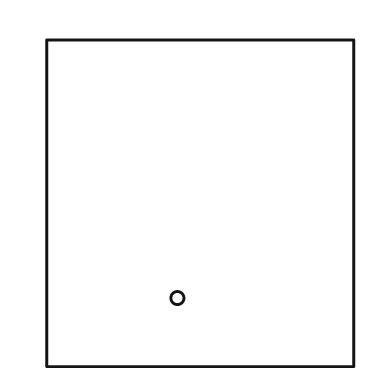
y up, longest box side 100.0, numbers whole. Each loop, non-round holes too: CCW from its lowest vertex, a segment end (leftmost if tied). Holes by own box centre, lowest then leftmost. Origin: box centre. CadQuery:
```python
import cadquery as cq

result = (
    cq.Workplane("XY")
    .moveTo(-47.0, -50.0)
    .lineTo(47.0, -50.0)
    .lineTo(47.0, 50.0)
    .lineTo(-47.0, 50.0)
    .close()
    .moveTo(-7.0, -29.0)
    .circle(2.0)
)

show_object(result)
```